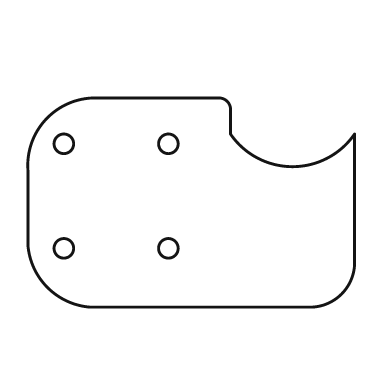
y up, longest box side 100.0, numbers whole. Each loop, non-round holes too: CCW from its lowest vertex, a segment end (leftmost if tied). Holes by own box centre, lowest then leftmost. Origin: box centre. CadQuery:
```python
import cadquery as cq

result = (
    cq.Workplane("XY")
    .moveTo(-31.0, -32.0)
    .lineTo(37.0, -32.0)
    .threePointArc((46.0, -28.0), (50.0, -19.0))
    .lineTo(50.0, 21.0)
    .threePointArc((31.0, 11.0), (12.0, 21.0))
    .lineTo(12.0, 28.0)
    .threePointArc((11.0, 31.0), (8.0, 32.0))
    .lineTo(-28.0, 32.0)
    .threePointArc((-44.0, 26.0), (-50.0, 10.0))
    .lineTo(-50.0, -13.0)
    .threePointArc((-44.0, -26.0), (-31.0, -32.0))
    .close()
    .moveTo(-39.0, -14.0)
    .circle(3.0)
    .moveTo(-7.0, -14.0)
    .circle(3.0)
    .moveTo(-39.0, 18.0)
    .circle(3.0)
    .moveTo(-7.0, 18.0)
    .circle(3.0)
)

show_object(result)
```